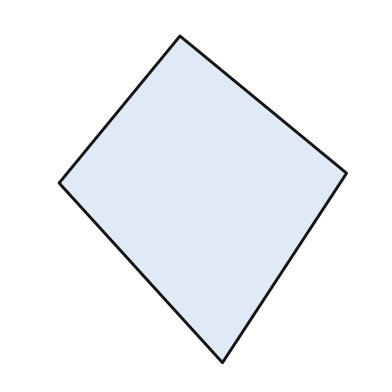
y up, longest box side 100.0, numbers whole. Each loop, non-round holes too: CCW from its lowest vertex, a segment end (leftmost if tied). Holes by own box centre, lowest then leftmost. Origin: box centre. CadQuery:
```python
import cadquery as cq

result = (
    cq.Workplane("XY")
    .moveTo(6.0, -50.0)
    .lineTo(44.0, 8.0)
    .lineTo(-7.0, 50.0)
    .lineTo(-44.0, 5.0)
    .close()
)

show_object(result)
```